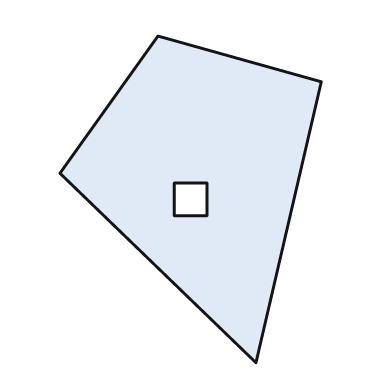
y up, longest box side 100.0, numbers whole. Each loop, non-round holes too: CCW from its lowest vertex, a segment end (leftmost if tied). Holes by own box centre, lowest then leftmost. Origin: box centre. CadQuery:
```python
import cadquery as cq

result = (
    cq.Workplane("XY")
    .moveTo(20.0, -50.0)
    .lineTo(40.0, 36.0)
    .lineTo(-10.0, 50.0)
    .lineTo(-40.0, 8.0)
    .close()
    .moveTo(-5.0, -5.0)
    .lineTo(5.0, -5.0)
    .lineTo(5.0, 5.0)
    .lineTo(-5.0, 5.0)
    .close()
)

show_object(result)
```